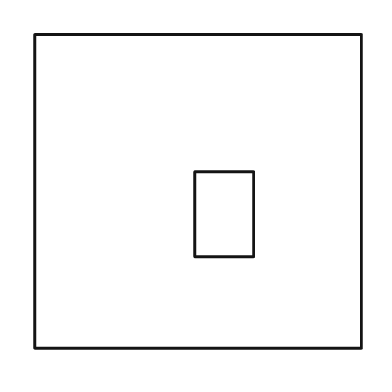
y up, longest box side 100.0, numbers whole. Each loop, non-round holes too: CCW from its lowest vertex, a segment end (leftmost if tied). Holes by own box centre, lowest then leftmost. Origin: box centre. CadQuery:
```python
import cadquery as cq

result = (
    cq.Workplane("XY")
    .moveTo(-50.0, -48.0)
    .lineTo(50.0, -48.0)
    .lineTo(50.0, 48.0)
    .lineTo(-50.0, 48.0)
    .close()
    .moveTo(-1.0, -20.0)
    .lineTo(17.0, -20.0)
    .lineTo(17.0, 6.0)
    .lineTo(-1.0, 6.0)
    .close()
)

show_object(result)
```